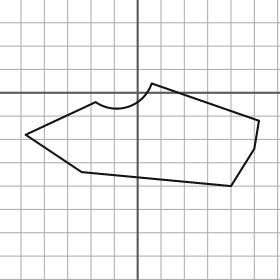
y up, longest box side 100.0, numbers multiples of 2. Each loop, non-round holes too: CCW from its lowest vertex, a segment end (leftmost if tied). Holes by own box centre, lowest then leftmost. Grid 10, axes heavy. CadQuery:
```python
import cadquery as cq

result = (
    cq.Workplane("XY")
    .moveTo(40.0, -40.0)
    .lineTo(50.0, -24.0)
    .lineTo(52.0, -12.0)
    .lineTo(6.0, 4.0)
    .threePointArc((-4.0, -6.0), (-18.0, -4.0))
    .lineTo(-48.0, -18.0)
    .lineTo(-24.0, -34.0)
    .close()
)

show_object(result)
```